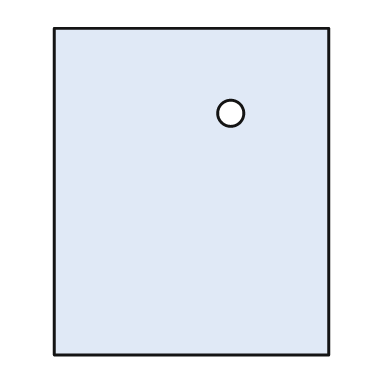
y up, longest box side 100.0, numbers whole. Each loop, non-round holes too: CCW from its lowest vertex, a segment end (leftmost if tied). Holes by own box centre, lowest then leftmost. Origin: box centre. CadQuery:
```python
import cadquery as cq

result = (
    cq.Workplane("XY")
    .moveTo(-42.0, -50.0)
    .lineTo(42.0, -50.0)
    .lineTo(42.0, 50.0)
    .lineTo(-42.0, 50.0)
    .close()
    .moveTo(12.0, 24.0)
    .circle(4.0)
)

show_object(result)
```